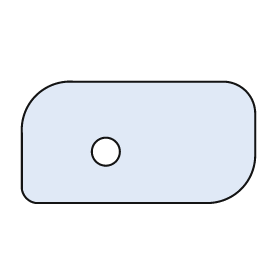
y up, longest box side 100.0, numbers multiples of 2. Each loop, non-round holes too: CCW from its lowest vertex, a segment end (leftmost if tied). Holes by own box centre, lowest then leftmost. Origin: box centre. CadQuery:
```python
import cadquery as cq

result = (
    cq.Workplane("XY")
    .moveTo(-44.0, -26.0)
    .lineTo(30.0, -26.0)
    .threePointArc((44.0, -20.0), (50.0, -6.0))
    .lineTo(50.0, 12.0)
    .threePointArc((46.0, 22.0), (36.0, 26.0))
    .lineTo(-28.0, 26.0)
    .threePointArc((-44.0, 20.0), (-50.0, 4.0))
    .lineTo(-50.0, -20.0)
    .threePointArc((-48.0, -24.0), (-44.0, -26.0))
    .close()
    .moveTo(-14.0, -4.0)
    .circle(6.0)
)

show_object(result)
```